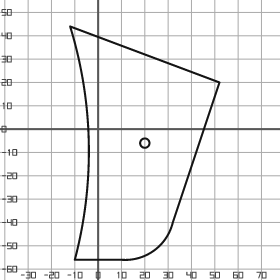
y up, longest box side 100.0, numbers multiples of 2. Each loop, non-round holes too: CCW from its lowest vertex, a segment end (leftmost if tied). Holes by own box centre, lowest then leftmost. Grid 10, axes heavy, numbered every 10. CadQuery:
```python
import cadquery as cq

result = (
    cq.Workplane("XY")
    .moveTo(-10.0, -56.0)
    .lineTo(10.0, -56.0)
    .threePointArc((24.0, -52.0), (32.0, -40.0))
    .lineTo(52.0, 20.0)
    .lineTo(-12.0, 44.0)
    .threePointArc((-4.0, -6.0), (-10.0, -56.0))
    .close()
    .moveTo(20.0, -6.0)
    .circle(2.0)
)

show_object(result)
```